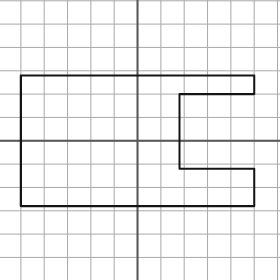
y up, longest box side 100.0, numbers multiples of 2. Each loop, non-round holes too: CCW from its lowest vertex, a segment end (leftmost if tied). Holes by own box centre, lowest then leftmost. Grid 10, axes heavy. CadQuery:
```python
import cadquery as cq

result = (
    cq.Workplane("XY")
    .moveTo(-50.0, -28.0)
    .lineTo(50.0, -28.0)
    .lineTo(50.0, -12.0)
    .lineTo(18.0, -12.0)
    .lineTo(18.0, 20.0)
    .lineTo(50.0, 20.0)
    .lineTo(50.0, 28.0)
    .lineTo(-50.0, 28.0)
    .close()
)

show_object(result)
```